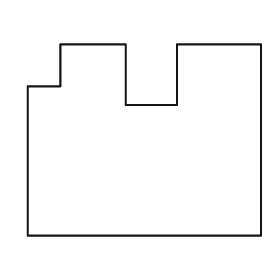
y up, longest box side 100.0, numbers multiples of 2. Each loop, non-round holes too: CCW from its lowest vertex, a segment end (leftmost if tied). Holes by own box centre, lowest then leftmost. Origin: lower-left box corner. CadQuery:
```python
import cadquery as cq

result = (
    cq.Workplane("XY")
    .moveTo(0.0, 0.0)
    .lineTo(100.0, 0.0)
    .lineTo(100.0, 82.0)
    .lineTo(64.0, 82.0)
    .lineTo(64.0, 56.0)
    .lineTo(42.0, 56.0)
    .lineTo(42.0, 82.0)
    .lineTo(14.0, 82.0)
    .lineTo(14.0, 64.0)
    .lineTo(0.0, 64.0)
    .close()
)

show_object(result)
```